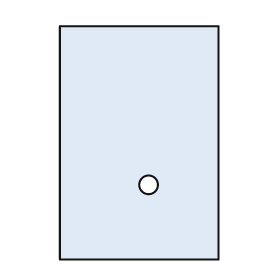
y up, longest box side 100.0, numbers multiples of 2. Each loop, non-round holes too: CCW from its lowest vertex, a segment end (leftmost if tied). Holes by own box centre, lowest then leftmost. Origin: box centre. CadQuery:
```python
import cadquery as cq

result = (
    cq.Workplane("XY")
    .moveTo(-34.0, -50.0)
    .lineTo(34.0, -50.0)
    .lineTo(34.0, 50.0)
    .lineTo(-34.0, 50.0)
    .close()
    .moveTo(4.0, -18.0)
    .circle(4.0)
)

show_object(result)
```